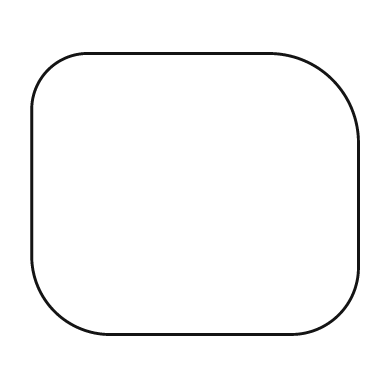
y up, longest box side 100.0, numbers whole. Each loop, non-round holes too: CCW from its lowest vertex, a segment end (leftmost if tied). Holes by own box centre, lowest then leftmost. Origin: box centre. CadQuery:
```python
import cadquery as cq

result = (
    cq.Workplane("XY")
    .moveTo(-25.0, -43.0)
    .lineTo(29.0, -43.0)
    .threePointArc((44.0, -37.0), (50.0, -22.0))
    .lineTo(50.0, 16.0)
    .threePointArc((42.0, 35.0), (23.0, 43.0))
    .lineTo(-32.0, 43.0)
    .threePointArc((-45.0, 38.0), (-50.0, 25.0))
    .lineTo(-50.0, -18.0)
    .threePointArc((-43.0, -36.0), (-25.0, -43.0))
    .close()
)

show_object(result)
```